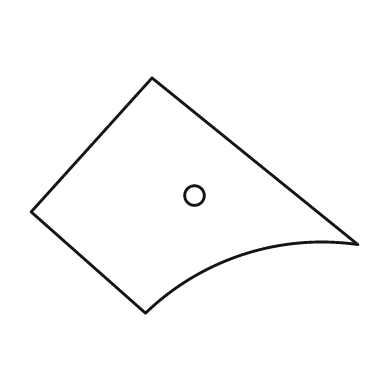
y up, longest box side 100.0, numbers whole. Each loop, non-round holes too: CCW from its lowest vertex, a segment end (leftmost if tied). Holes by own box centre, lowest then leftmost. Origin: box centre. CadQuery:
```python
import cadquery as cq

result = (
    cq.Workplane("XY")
    .moveTo(-15.0, -36.0)
    .threePointArc((15.0, -18.0), (50.0, -15.0))
    .lineTo(-13.0, 36.0)
    .lineTo(-50.0, -5.0)
    .close()
    .moveTo(0.0, 0.0)
    .circle(3.0)
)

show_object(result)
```